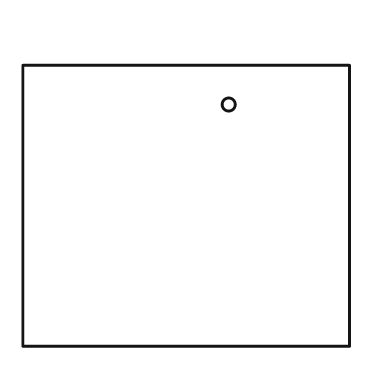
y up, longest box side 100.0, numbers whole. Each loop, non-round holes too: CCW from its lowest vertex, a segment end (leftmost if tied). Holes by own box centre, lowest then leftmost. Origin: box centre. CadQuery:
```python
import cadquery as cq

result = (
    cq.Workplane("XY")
    .moveTo(-50.0, -43.0)
    .lineTo(50.0, -43.0)
    .lineTo(50.0, 43.0)
    .lineTo(-50.0, 43.0)
    .close()
    .moveTo(13.0, 31.0)
    .circle(2.0)
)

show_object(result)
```